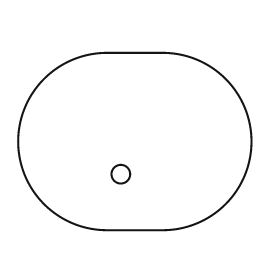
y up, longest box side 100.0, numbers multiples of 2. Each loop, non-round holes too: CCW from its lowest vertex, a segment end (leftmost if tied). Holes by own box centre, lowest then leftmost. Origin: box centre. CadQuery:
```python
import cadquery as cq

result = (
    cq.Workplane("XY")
    .moveTo(-12.0, -38.0)
    .lineTo(12.0, -38.0)
    .threePointArc((50.0, 0.0), (12.0, 38.0))
    .lineTo(-12.0, 38.0)
    .threePointArc((-50.0, 0.0), (-12.0, -38.0))
    .close()
    .moveTo(-6.0, -14.0)
    .circle(4.0)
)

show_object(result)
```